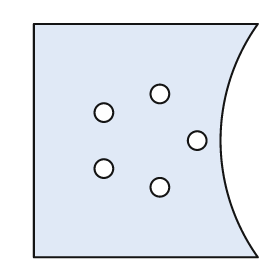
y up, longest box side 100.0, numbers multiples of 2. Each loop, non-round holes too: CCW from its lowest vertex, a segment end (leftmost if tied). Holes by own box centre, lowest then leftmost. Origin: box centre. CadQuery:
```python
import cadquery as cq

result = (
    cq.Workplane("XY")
    .moveTo(-48.0, -50.0)
    .lineTo(48.0, -50.0)
    .threePointArc((32.0, 0.0), (48.0, 50.0))
    .lineTo(-48.0, 50.0)
    .close()
    .moveTo(6.0, -20.0)
    .circle(4.0)
    .moveTo(-18.0, -12.0)
    .circle(4.0)
    .moveTo(22.0, 0.0)
    .circle(4.0)
    .moveTo(-18.0, 12.0)
    .circle(4.0)
    .moveTo(6.0, 20.0)
    .circle(4.0)
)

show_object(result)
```